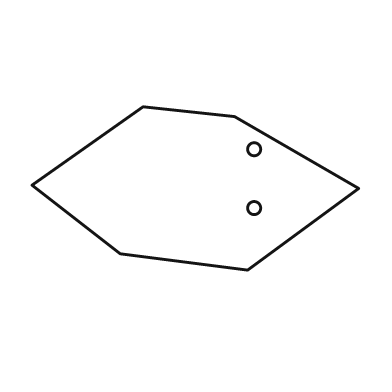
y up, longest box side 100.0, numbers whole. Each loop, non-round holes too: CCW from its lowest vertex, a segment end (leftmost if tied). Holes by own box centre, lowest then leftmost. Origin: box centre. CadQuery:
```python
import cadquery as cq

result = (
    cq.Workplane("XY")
    .moveTo(16.0, -25.0)
    .lineTo(50.0, 0.0)
    .lineTo(12.0, 22.0)
    .lineTo(-16.0, 25.0)
    .lineTo(-50.0, 1.0)
    .lineTo(-23.0, -20.0)
    .close()
    .moveTo(18.0, -6.0)
    .circle(2.0)
    .moveTo(18.0, 12.0)
    .circle(2.0)
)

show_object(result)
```